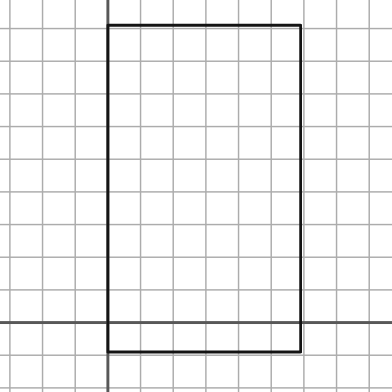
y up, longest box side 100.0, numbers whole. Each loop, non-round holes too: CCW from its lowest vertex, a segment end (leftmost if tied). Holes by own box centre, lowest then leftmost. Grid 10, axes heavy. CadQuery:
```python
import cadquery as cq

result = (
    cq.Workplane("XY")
    .moveTo(0.0, -9.0)
    .lineTo(59.0, -9.0)
    .lineTo(59.0, 91.0)
    .lineTo(0.0, 91.0)
    .close()
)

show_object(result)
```